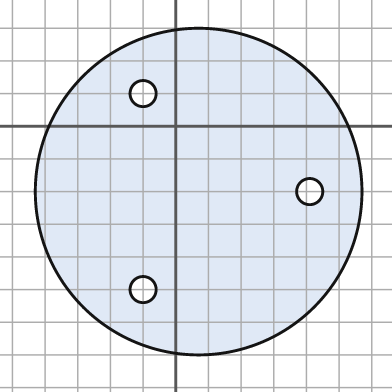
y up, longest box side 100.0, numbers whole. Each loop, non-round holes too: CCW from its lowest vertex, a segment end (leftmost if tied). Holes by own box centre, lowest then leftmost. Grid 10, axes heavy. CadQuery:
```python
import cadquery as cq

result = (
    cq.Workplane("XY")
    .moveTo(7.0, -20.0)
    .circle(50.0)
    .moveTo(-10.0, -50.0)
    .circle(4.0)
    .moveTo(41.0, -20.0)
    .circle(4.0)
    .moveTo(-10.0, 10.0)
    .circle(4.0)
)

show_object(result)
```